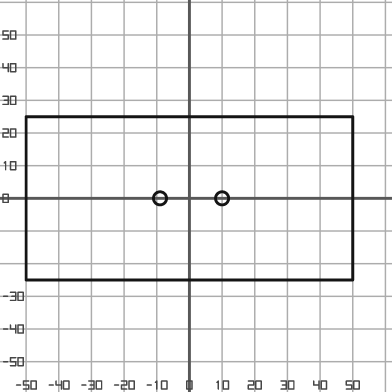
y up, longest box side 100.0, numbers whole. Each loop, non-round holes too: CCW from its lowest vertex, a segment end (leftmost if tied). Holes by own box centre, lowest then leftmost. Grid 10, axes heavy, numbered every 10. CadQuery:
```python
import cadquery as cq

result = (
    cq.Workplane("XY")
    .moveTo(-50.0, -25.0)
    .lineTo(50.0, -25.0)
    .lineTo(50.0, 25.0)
    .lineTo(-50.0, 25.0)
    .close()
    .moveTo(-9.0, 0.0)
    .circle(2.0)
    .moveTo(10.0, 0.0)
    .circle(2.0)
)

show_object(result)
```